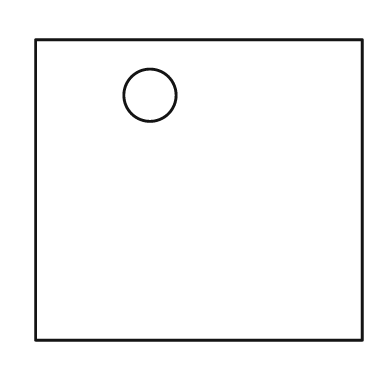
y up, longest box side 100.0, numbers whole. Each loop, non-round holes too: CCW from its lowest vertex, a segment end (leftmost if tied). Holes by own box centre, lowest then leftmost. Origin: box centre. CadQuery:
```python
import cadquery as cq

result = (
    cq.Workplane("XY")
    .moveTo(-50.0, -46.0)
    .lineTo(50.0, -46.0)
    .lineTo(50.0, 46.0)
    .lineTo(-50.0, 46.0)
    .close()
    .moveTo(-15.0, 29.0)
    .circle(8.0)
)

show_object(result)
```